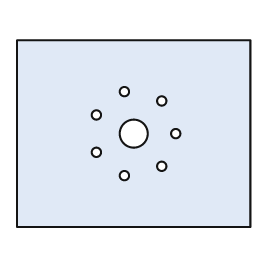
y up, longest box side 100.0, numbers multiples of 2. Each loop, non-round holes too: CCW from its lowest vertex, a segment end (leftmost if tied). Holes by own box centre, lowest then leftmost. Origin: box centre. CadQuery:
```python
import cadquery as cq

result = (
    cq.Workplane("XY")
    .moveTo(-50.0, -40.0)
    .lineTo(50.0, -40.0)
    .lineTo(50.0, 40.0)
    .lineTo(-50.0, 40.0)
    .close()
    .moveTo(-4.0, -18.0)
    .circle(2.0)
    .moveTo(12.0, -14.0)
    .circle(2.0)
    .moveTo(-16.0, -8.0)
    .circle(2.0)
    .moveTo(0.0, 0.0)
    .circle(6.0)
    .moveTo(18.0, 0.0)
    .circle(2.0)
    .moveTo(-16.0, 8.0)
    .circle(2.0)
    .moveTo(12.0, 14.0)
    .circle(2.0)
    .moveTo(-4.0, 18.0)
    .circle(2.0)
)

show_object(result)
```